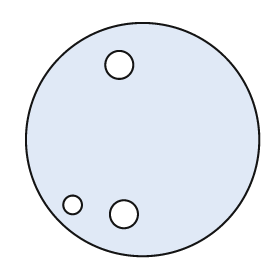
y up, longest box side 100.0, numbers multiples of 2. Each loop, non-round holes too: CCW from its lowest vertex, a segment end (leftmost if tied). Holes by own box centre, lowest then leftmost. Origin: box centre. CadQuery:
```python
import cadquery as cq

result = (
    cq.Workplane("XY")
    .moveTo(0.0, 0.0)
    .circle(50.0)
    .moveTo(-8.0, -32.0)
    .circle(6.0)
    .moveTo(-30.0, -28.0)
    .circle(4.0)
    .moveTo(-10.0, 32.0)
    .circle(6.0)
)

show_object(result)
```